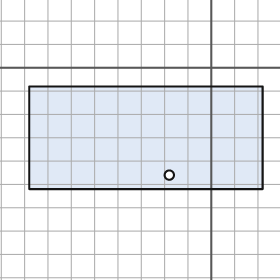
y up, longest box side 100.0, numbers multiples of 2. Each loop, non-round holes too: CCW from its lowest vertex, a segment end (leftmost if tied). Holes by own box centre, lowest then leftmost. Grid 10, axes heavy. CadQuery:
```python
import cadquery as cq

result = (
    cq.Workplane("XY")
    .moveTo(-78.0, -52.0)
    .lineTo(22.0, -52.0)
    .lineTo(22.0, -8.0)
    .lineTo(-78.0, -8.0)
    .close()
    .moveTo(-18.0, -46.0)
    .circle(2.0)
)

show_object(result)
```